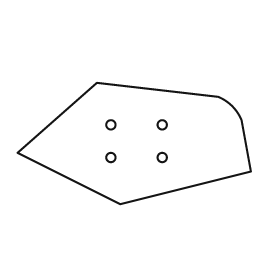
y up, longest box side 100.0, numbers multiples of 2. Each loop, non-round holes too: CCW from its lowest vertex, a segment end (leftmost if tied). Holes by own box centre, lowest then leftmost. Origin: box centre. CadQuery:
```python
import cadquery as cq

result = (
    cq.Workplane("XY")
    .moveTo(-6.0, -26.0)
    .lineTo(50.0, -12.0)
    .lineTo(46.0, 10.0)
    .threePointArc((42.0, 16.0), (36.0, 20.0))
    .lineTo(-16.0, 26.0)
    .lineTo(-50.0, -4.0)
    .close()
    .moveTo(-10.0, -6.0)
    .circle(2.0)
    .moveTo(12.0, -6.0)
    .circle(2.0)
    .moveTo(-10.0, 8.0)
    .circle(2.0)
    .moveTo(12.0, 8.0)
    .circle(2.0)
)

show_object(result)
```